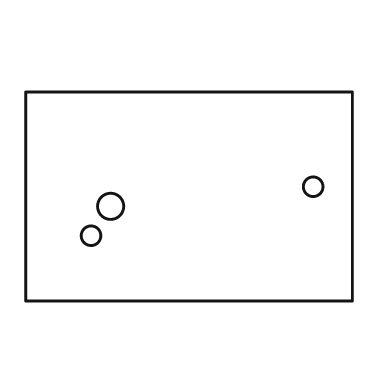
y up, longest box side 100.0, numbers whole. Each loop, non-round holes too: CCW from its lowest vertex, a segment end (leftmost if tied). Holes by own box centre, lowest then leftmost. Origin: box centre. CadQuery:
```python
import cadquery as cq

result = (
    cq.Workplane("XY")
    .moveTo(-50.0, -32.0)
    .lineTo(50.0, -32.0)
    .lineTo(50.0, 32.0)
    .lineTo(-50.0, 32.0)
    .close()
    .moveTo(-30.0, -12.0)
    .circle(3.0)
    .moveTo(-24.0, -3.0)
    .circle(4.0)
    .moveTo(38.0, 3.0)
    .circle(3.0)
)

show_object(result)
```